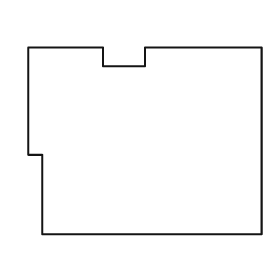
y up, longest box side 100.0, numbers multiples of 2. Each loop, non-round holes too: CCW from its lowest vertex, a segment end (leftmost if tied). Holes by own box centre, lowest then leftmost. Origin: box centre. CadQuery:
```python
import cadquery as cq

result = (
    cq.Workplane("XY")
    .moveTo(-44.0, -40.0)
    .lineTo(50.0, -40.0)
    .lineTo(50.0, 40.0)
    .lineTo(0.0, 40.0)
    .lineTo(0.0, 32.0)
    .lineTo(-18.0, 32.0)
    .lineTo(-18.0, 40.0)
    .lineTo(-50.0, 40.0)
    .lineTo(-50.0, -6.0)
    .lineTo(-44.0, -6.0)
    .close()
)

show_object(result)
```